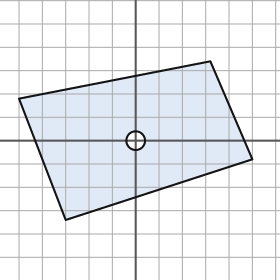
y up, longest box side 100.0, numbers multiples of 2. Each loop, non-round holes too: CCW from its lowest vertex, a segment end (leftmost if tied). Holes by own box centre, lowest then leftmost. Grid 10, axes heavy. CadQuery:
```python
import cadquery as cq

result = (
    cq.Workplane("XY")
    .moveTo(-30.0, -34.0)
    .lineTo(50.0, -8.0)
    .lineTo(32.0, 34.0)
    .lineTo(-50.0, 18.0)
    .close()
    .moveTo(0.0, 0.0)
    .circle(4.0)
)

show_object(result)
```